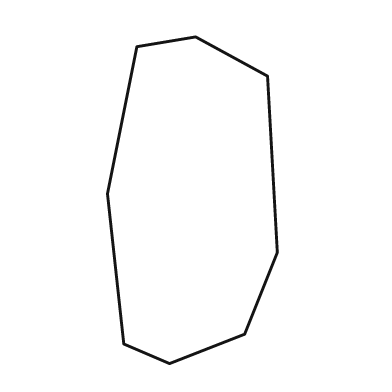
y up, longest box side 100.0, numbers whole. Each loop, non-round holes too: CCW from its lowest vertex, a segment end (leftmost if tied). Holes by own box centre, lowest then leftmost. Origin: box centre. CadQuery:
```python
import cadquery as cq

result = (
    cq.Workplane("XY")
    .moveTo(-7.0, -50.0)
    .lineTo(16.0, -41.0)
    .lineTo(26.0, -16.0)
    .lineTo(23.0, 38.0)
    .lineTo(1.0, 50.0)
    .lineTo(-17.0, 47.0)
    .lineTo(-26.0, 2.0)
    .lineTo(-21.0, -44.0)
    .close()
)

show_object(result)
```